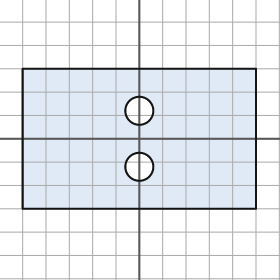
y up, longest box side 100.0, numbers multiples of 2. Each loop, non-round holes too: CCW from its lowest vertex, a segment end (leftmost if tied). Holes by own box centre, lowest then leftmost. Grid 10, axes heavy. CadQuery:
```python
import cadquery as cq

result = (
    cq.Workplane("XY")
    .moveTo(-50.0, -30.0)
    .lineTo(50.0, -30.0)
    .lineTo(50.0, 30.0)
    .lineTo(-50.0, 30.0)
    .close()
    .moveTo(0.0, -12.0)
    .circle(6.0)
    .moveTo(0.0, 12.0)
    .circle(6.0)
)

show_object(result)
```